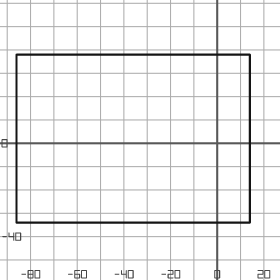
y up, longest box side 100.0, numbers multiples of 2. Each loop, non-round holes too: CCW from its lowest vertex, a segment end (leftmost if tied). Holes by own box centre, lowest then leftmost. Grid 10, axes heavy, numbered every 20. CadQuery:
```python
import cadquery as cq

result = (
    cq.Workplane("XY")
    .moveTo(-86.0, -34.0)
    .lineTo(14.0, -34.0)
    .lineTo(14.0, 38.0)
    .lineTo(-86.0, 38.0)
    .close()
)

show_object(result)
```